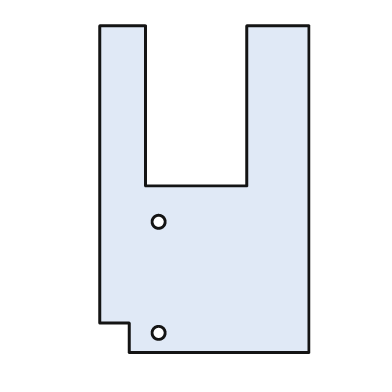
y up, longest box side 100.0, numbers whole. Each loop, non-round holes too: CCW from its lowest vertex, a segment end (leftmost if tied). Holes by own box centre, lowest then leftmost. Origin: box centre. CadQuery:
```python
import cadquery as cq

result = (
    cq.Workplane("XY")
    .moveTo(-23.0, -50.0)
    .lineTo(32.0, -50.0)
    .lineTo(32.0, 50.0)
    .lineTo(13.0, 50.0)
    .lineTo(13.0, 1.0)
    .lineTo(-18.0, 1.0)
    .lineTo(-18.0, 50.0)
    .lineTo(-32.0, 50.0)
    .lineTo(-32.0, -41.0)
    .lineTo(-23.0, -41.0)
    .close()
    .moveTo(-14.0, -44.0)
    .circle(2.0)
    .moveTo(-14.0, -10.0)
    .circle(2.0)
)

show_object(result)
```